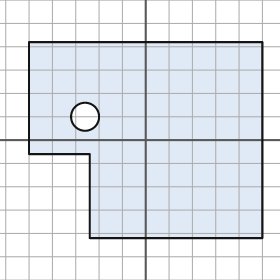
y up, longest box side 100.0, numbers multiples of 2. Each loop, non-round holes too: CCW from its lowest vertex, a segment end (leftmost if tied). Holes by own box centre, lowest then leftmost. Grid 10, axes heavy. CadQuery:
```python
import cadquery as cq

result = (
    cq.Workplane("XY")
    .moveTo(-24.0, -42.0)
    .lineTo(50.0, -42.0)
    .lineTo(50.0, 42.0)
    .lineTo(-50.0, 42.0)
    .lineTo(-50.0, -6.0)
    .lineTo(-24.0, -6.0)
    .close()
    .moveTo(-26.0, 10.0)
    .circle(6.0)
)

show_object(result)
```